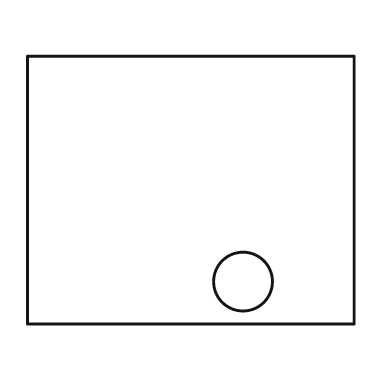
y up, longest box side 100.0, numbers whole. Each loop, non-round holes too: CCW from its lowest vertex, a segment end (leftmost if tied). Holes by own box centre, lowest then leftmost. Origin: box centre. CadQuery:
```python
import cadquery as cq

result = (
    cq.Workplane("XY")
    .moveTo(-50.0, -41.0)
    .lineTo(50.0, -41.0)
    .lineTo(50.0, 41.0)
    .lineTo(-50.0, 41.0)
    .close()
    .moveTo(16.0, -28.0)
    .circle(9.0)
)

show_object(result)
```